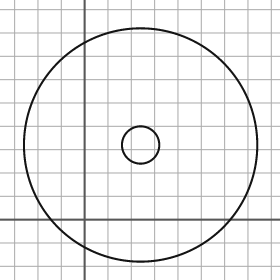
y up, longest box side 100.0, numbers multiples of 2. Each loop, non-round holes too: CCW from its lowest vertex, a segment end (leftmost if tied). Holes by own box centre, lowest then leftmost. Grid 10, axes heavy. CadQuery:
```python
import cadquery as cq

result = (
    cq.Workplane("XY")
    .moveTo(24.0, 32.0)
    .circle(50.0)
    .moveTo(24.0, 32.0)
    .circle(8.0)
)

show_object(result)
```